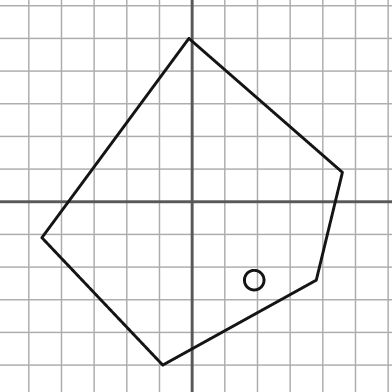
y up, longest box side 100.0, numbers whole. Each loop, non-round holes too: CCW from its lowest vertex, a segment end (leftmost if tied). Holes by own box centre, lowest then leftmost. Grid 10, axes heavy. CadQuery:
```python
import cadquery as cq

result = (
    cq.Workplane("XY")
    .moveTo(-9.0, -50.0)
    .lineTo(38.0, -24.0)
    .lineTo(46.0, 9.0)
    .lineTo(-1.0, 50.0)
    .lineTo(-46.0, -11.0)
    .close()
    .moveTo(19.0, -24.0)
    .circle(3.0)
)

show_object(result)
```